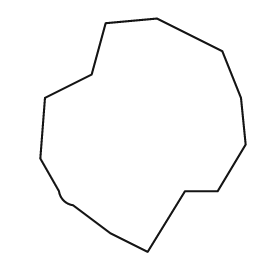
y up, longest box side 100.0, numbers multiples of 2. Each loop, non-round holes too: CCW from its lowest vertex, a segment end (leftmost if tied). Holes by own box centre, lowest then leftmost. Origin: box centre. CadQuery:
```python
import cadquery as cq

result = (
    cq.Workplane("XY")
    .moveTo(2.0, -50.0)
    .lineTo(18.0, -24.0)
    .lineTo(32.0, -24.0)
    .lineTo(44.0, -4.0)
    .lineTo(42.0, 16.0)
    .lineTo(34.0, 36.0)
    .lineTo(6.0, 50.0)
    .lineTo(-16.0, 48.0)
    .lineTo(-22.0, 26.0)
    .lineTo(-42.0, 16.0)
    .lineTo(-44.0, -10.0)
    .lineTo(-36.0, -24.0)
    .threePointArc((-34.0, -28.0), (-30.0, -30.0))
    .lineTo(-14.0, -42.0)
    .close()
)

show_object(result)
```